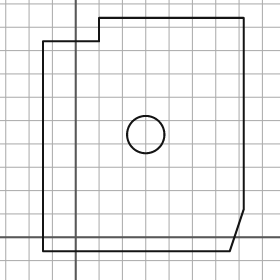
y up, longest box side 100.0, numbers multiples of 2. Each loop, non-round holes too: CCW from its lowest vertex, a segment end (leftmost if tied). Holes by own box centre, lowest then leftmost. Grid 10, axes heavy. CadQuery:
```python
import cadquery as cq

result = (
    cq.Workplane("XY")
    .moveTo(-14.0, -6.0)
    .lineTo(66.0, -6.0)
    .lineTo(72.0, 12.0)
    .lineTo(72.0, 94.0)
    .lineTo(10.0, 94.0)
    .lineTo(10.0, 84.0)
    .lineTo(-14.0, 84.0)
    .close()
    .moveTo(30.0, 44.0)
    .circle(8.0)
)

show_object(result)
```